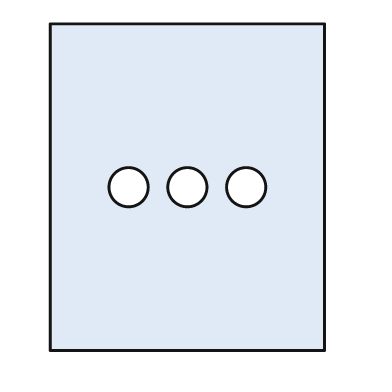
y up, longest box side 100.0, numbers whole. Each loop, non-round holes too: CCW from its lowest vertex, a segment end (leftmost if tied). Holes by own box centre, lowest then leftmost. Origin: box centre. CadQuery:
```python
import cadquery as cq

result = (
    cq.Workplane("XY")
    .moveTo(-42.0, -50.0)
    .lineTo(42.0, -50.0)
    .lineTo(42.0, 50.0)
    .lineTo(-42.0, 50.0)
    .close()
    .moveTo(-18.0, 0.0)
    .circle(6.0)
    .moveTo(0.0, 0.0)
    .circle(6.0)
    .moveTo(18.0, 0.0)
    .circle(6.0)
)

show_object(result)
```